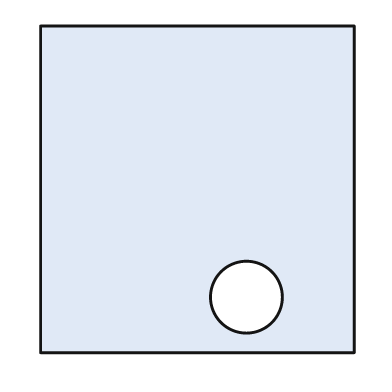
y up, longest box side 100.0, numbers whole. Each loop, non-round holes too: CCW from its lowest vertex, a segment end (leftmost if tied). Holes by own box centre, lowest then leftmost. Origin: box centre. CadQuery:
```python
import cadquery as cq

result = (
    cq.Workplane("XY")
    .moveTo(-48.0, -50.0)
    .lineTo(48.0, -50.0)
    .lineTo(48.0, 50.0)
    .lineTo(-48.0, 50.0)
    .close()
    .moveTo(15.0, -33.0)
    .circle(11.0)
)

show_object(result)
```